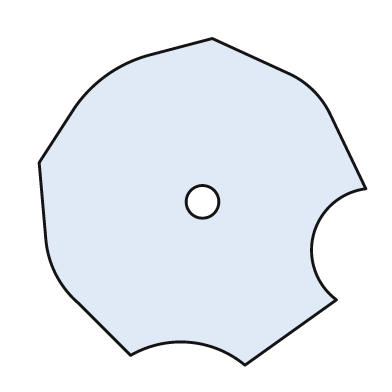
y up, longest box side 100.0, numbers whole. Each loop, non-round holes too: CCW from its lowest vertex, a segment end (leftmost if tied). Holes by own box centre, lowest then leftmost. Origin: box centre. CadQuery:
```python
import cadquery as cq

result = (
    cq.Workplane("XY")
    .moveTo(13.0, -50.0)
    .lineTo(41.0, -30.0)
    .threePointArc((34.0, -10.0), (50.0, 4.0))
    .lineTo(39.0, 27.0)
    .threePointArc((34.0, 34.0), (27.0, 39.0))
    .lineTo(3.0, 50.0)
    .lineTo(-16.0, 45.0)
    .threePointArc((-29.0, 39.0), (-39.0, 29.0))
    .lineTo(-50.0, 12.0)
    .lineTo(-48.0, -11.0)
    .threePointArc((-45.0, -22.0), (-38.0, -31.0))
    .lineTo(-22.0, -47.0)
    .threePointArc((-4.0, -43.0), (13.0, -50.0))
    .close()
    .moveTo(0.0, 0.0)
    .circle(5.0)
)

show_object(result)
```